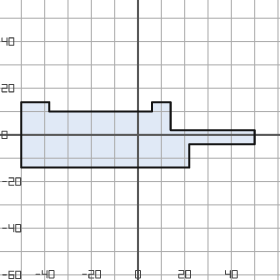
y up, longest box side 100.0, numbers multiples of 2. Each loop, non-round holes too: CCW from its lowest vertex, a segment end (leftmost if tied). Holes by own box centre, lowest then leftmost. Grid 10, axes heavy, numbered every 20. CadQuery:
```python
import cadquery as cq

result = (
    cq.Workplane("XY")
    .moveTo(-50.0, -14.0)
    .lineTo(22.0, -14.0)
    .lineTo(22.0, -4.0)
    .lineTo(50.0, -4.0)
    .lineTo(50.0, 2.0)
    .lineTo(14.0, 2.0)
    .lineTo(14.0, 14.0)
    .lineTo(6.0, 14.0)
    .lineTo(6.0, 10.0)
    .lineTo(-38.0, 10.0)
    .lineTo(-38.0, 14.0)
    .lineTo(-50.0, 14.0)
    .close()
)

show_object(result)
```